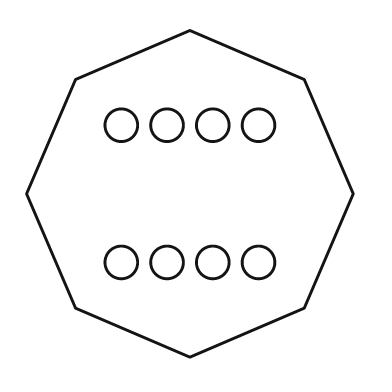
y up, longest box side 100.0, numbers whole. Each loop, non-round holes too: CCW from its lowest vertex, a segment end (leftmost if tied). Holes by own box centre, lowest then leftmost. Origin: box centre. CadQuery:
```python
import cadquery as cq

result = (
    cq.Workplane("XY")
    .moveTo(0.0, -50.0)
    .lineTo(35.0, -35.0)
    .lineTo(50.0, 0.0)
    .lineTo(35.0, 35.0)
    .lineTo(0.0, 50.0)
    .lineTo(-35.0, 35.0)
    .lineTo(-50.0, 0.0)
    .lineTo(-35.0, -35.0)
    .close()
    .moveTo(-21.0, -21.0)
    .circle(5.0)
    .moveTo(-7.0, -21.0)
    .circle(5.0)
    .moveTo(7.0, -21.0)
    .circle(5.0)
    .moveTo(21.0, -21.0)
    .circle(5.0)
    .moveTo(-21.0, 21.0)
    .circle(5.0)
    .moveTo(-7.0, 21.0)
    .circle(5.0)
    .moveTo(7.0, 21.0)
    .circle(5.0)
    .moveTo(21.0, 21.0)
    .circle(5.0)
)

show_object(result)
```